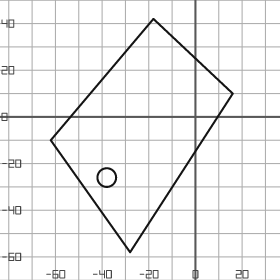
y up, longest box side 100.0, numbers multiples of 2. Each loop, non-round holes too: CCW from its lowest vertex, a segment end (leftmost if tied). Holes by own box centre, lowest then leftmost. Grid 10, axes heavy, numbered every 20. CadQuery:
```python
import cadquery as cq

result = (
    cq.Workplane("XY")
    .moveTo(-28.0, -58.0)
    .lineTo(16.0, 10.0)
    .lineTo(-18.0, 42.0)
    .lineTo(-62.0, -10.0)
    .close()
    .moveTo(-38.0, -26.0)
    .circle(4.0)
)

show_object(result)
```